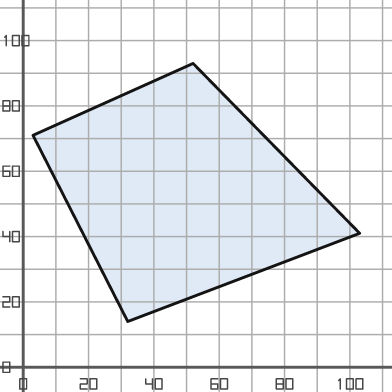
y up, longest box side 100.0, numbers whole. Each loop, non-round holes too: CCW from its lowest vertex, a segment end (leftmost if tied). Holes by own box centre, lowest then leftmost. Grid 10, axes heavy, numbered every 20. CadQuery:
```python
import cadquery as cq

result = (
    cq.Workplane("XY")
    .moveTo(32.0, 14.0)
    .lineTo(103.0, 41.0)
    .lineTo(52.0, 93.0)
    .lineTo(3.0, 71.0)
    .close()
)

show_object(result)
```